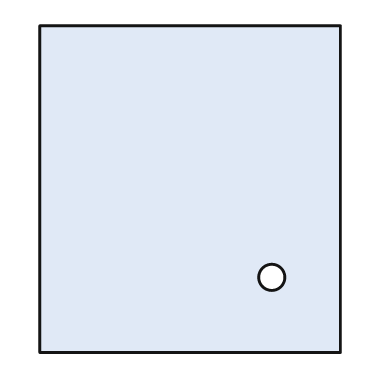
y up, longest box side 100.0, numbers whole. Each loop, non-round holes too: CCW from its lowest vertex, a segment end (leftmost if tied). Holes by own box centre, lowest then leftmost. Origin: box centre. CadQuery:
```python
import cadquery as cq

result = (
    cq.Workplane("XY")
    .moveTo(-46.0, -50.0)
    .lineTo(46.0, -50.0)
    .lineTo(46.0, 50.0)
    .lineTo(-46.0, 50.0)
    .close()
    .moveTo(25.0, -27.0)
    .circle(4.0)
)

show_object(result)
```